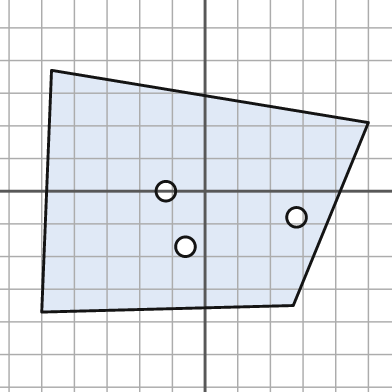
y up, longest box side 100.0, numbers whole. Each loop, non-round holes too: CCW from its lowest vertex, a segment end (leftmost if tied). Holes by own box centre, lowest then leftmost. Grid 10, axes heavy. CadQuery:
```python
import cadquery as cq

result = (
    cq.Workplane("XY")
    .moveTo(-50.0, -37.0)
    .lineTo(27.0, -35.0)
    .lineTo(50.0, 21.0)
    .lineTo(-47.0, 37.0)
    .close()
    .moveTo(-6.0, -17.0)
    .circle(3.0)
    .moveTo(28.0, -8.0)
    .circle(3.0)
    .moveTo(-12.0, 0.0)
    .circle(3.0)
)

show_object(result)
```